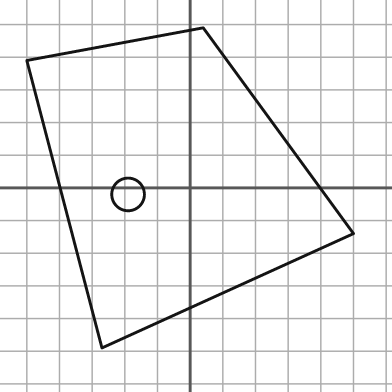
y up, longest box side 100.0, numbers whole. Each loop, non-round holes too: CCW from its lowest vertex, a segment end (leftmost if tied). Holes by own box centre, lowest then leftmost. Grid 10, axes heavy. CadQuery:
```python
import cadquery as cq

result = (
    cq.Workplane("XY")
    .moveTo(-27.0, -49.0)
    .lineTo(50.0, -14.0)
    .lineTo(4.0, 49.0)
    .lineTo(-50.0, 39.0)
    .close()
    .moveTo(-19.0, -2.0)
    .circle(5.0)
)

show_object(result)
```